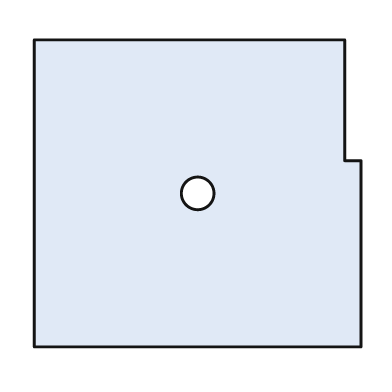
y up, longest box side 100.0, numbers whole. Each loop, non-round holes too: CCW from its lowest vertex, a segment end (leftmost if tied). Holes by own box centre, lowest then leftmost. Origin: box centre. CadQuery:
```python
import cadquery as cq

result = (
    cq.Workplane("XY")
    .moveTo(-50.0, -47.0)
    .lineTo(50.0, -47.0)
    .lineTo(50.0, 10.0)
    .lineTo(45.0, 10.0)
    .lineTo(45.0, 47.0)
    .lineTo(-50.0, 47.0)
    .close()
    .moveTo(0.0, 0.0)
    .circle(5.0)
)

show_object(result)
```